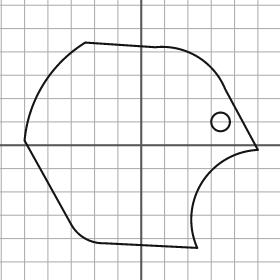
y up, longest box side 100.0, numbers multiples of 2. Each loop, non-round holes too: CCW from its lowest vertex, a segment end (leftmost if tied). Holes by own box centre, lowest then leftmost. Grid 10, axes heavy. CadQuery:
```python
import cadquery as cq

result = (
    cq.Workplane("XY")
    .moveTo(24.0, -44.0)
    .threePointArc((26.0, -16.0), (50.0, -2.0))
    .lineTo(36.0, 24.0)
    .threePointArc((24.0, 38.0), (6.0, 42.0))
    .lineTo(-24.0, 44.0)
    .threePointArc((-42.0, 26.0), (-50.0, 2.0))
    .lineTo(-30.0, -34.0)
    .threePointArc((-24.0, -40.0), (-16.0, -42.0))
    .close()
    .moveTo(34.0, 10.0)
    .circle(4.0)
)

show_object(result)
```